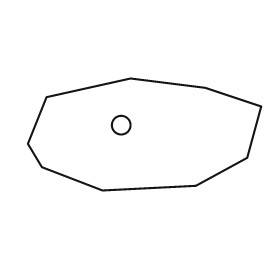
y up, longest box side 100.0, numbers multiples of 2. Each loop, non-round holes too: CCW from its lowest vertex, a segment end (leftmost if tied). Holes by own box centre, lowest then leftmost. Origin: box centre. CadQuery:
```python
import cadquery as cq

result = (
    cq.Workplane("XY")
    .moveTo(-18.0, -24.0)
    .lineTo(22.0, -22.0)
    .lineTo(44.0, -10.0)
    .lineTo(50.0, 12.0)
    .lineTo(26.0, 20.0)
    .lineTo(-6.0, 24.0)
    .lineTo(-42.0, 16.0)
    .lineTo(-50.0, -4.0)
    .lineTo(-44.0, -14.0)
    .close()
    .moveTo(-10.0, 4.0)
    .circle(4.0)
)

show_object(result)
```